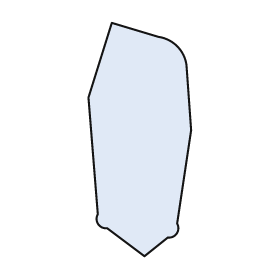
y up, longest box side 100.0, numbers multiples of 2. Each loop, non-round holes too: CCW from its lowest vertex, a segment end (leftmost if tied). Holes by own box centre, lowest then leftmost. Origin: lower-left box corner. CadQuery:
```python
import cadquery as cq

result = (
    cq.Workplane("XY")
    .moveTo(24.0, 0.0)
    .lineTo(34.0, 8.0)
    .threePointArc((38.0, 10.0), (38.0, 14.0))
    .lineTo(44.0, 54.0)
    .lineTo(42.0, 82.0)
    .threePointArc((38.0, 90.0), (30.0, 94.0))
    .lineTo(10.0, 100.0)
    .lineTo(0.0, 68.0)
    .lineTo(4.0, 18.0)
    .threePointArc((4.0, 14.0), (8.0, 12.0))
    .close()
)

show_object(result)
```